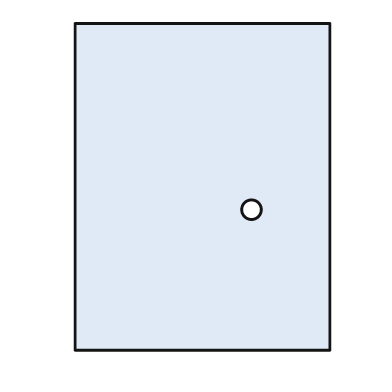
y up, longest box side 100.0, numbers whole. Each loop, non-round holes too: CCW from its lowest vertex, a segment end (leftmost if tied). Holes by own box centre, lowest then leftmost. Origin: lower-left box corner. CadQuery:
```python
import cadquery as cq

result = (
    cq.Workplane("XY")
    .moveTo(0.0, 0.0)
    .lineTo(78.0, 0.0)
    .lineTo(78.0, 100.0)
    .lineTo(0.0, 100.0)
    .close()
    .moveTo(54.0, 43.0)
    .circle(3.0)
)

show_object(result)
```